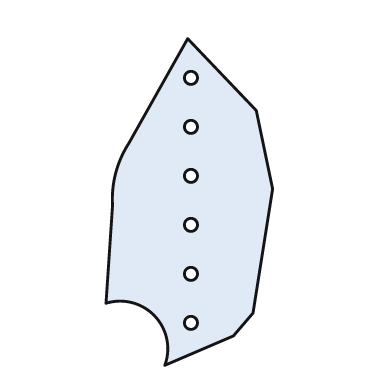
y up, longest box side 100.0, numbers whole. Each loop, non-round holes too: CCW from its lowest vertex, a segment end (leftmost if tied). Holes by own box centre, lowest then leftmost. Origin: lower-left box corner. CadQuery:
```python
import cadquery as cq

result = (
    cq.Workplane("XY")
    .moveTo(18.0, 0.0)
    .lineTo(39.0, 9.0)
    .lineTo(45.0, 16.0)
    .lineTo(51.0, 54.0)
    .lineTo(46.0, 78.0)
    .lineTo(25.0, 100.0)
    .lineTo(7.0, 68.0)
    .threePointArc((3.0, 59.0), (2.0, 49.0))
    .lineTo(0.0, 19.0)
    .threePointArc((15.0, 15.0), (18.0, 0.0))
    .close()
    .moveTo(26.0, 13.0)
    .circle(2.0)
    .moveTo(26.0, 28.0)
    .circle(2.0)
    .moveTo(26.0, 43.0)
    .circle(2.0)
    .moveTo(26.0, 58.0)
    .circle(2.0)
    .moveTo(26.0, 73.0)
    .circle(2.0)
    .moveTo(26.0, 88.0)
    .circle(2.0)
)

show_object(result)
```